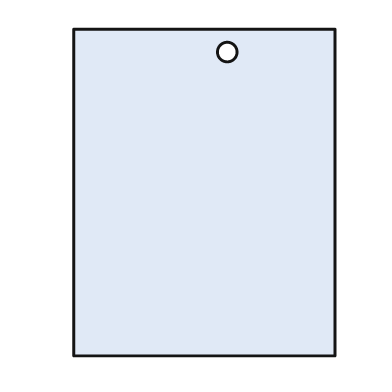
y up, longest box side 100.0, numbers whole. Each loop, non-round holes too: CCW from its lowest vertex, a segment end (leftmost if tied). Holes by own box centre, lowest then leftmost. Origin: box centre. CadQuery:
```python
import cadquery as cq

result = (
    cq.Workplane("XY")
    .moveTo(-40.0, -50.0)
    .lineTo(40.0, -50.0)
    .lineTo(40.0, 50.0)
    .lineTo(-40.0, 50.0)
    .close()
    .moveTo(7.0, 43.0)
    .circle(3.0)
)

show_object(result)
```